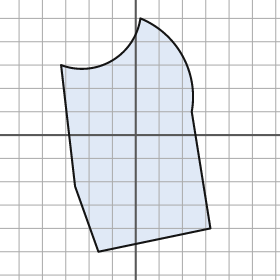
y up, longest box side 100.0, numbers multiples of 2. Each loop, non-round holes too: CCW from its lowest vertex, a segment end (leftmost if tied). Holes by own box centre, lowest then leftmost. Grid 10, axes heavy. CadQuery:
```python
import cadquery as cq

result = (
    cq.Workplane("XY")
    .moveTo(-16.0, -50.0)
    .lineTo(32.0, -40.0)
    .lineTo(24.0, 10.0)
    .threePointArc((20.0, 34.0), (2.0, 50.0))
    .threePointArc((-10.0, 32.0), (-32.0, 30.0))
    .lineTo(-26.0, -22.0)
    .close()
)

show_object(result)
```